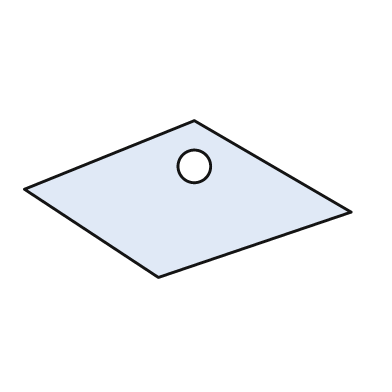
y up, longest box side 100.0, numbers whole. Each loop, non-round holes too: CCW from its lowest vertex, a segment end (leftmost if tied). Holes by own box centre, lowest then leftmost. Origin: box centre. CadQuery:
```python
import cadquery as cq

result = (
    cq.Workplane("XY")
    .moveTo(-9.0, -24.0)
    .lineTo(50.0, -4.0)
    .lineTo(2.0, 24.0)
    .lineTo(-50.0, 3.0)
    .close()
    .moveTo(2.0, 10.0)
    .circle(5.0)
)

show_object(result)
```